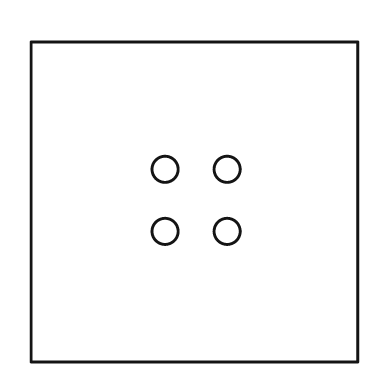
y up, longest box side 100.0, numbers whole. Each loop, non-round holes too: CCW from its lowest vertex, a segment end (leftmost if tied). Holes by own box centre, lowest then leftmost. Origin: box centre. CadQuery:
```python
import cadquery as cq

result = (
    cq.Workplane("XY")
    .moveTo(-50.0, -49.0)
    .lineTo(50.0, -49.0)
    .lineTo(50.0, 49.0)
    .lineTo(-50.0, 49.0)
    .close()
    .moveTo(-9.0, -9.0)
    .circle(4.0)
    .moveTo(10.0, -9.0)
    .circle(4.0)
    .moveTo(-9.0, 10.0)
    .circle(4.0)
    .moveTo(10.0, 10.0)
    .circle(4.0)
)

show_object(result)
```